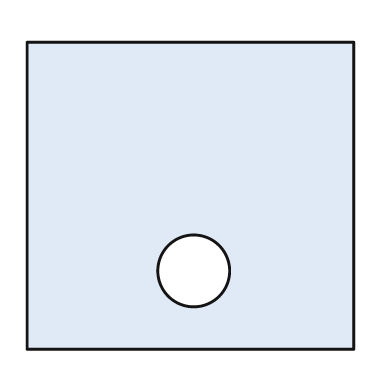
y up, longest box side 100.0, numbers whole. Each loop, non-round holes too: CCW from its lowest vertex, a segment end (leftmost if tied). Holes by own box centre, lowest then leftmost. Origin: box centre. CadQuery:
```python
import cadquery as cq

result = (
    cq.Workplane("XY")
    .moveTo(-50.0, -47.0)
    .lineTo(50.0, -47.0)
    .lineTo(50.0, 47.0)
    .lineTo(-50.0, 47.0)
    .close()
    .moveTo(1.0, -23.0)
    .circle(11.0)
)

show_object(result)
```